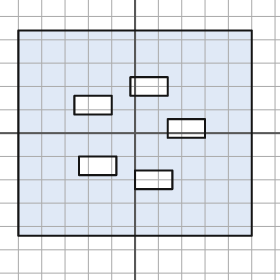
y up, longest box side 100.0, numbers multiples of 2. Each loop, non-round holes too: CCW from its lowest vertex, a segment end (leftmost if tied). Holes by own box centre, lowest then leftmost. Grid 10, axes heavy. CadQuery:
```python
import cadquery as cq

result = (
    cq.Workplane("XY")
    .moveTo(-50.0, -44.0)
    .lineTo(50.0, -44.0)
    .lineTo(50.0, 44.0)
    .lineTo(-50.0, 44.0)
    .close()
    .moveTo(0.0, -24.0)
    .lineTo(16.0, -24.0)
    .lineTo(16.0, -16.0)
    .lineTo(0.0, -16.0)
    .close()
    .moveTo(-24.0, -18.0)
    .lineTo(-8.0, -18.0)
    .lineTo(-8.0, -10.0)
    .lineTo(-24.0, -10.0)
    .close()
    .moveTo(14.0, -2.0)
    .lineTo(30.0, -2.0)
    .lineTo(30.0, 6.0)
    .lineTo(14.0, 6.0)
    .close()
    .moveTo(-26.0, 8.0)
    .lineTo(-10.0, 8.0)
    .lineTo(-10.0, 16.0)
    .lineTo(-26.0, 16.0)
    .close()
    .moveTo(-2.0, 16.0)
    .lineTo(14.0, 16.0)
    .lineTo(14.0, 24.0)
    .lineTo(-2.0, 24.0)
    .close()
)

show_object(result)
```